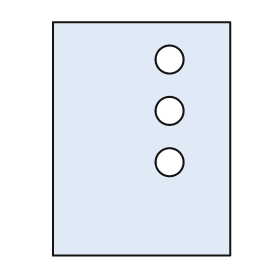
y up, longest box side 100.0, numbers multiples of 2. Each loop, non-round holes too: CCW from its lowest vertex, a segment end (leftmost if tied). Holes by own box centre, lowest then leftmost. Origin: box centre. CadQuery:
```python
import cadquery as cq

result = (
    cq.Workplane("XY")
    .moveTo(-38.0, -50.0)
    .lineTo(38.0, -50.0)
    .lineTo(38.0, 50.0)
    .lineTo(-38.0, 50.0)
    .close()
    .moveTo(12.0, -10.0)
    .circle(6.0)
    .moveTo(12.0, 12.0)
    .circle(6.0)
    .moveTo(12.0, 34.0)
    .circle(6.0)
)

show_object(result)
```